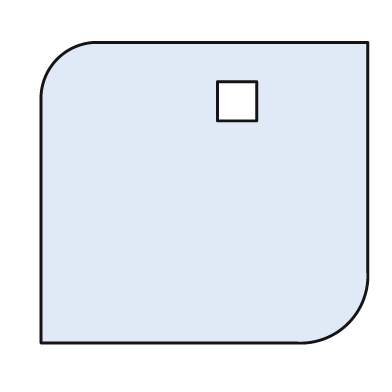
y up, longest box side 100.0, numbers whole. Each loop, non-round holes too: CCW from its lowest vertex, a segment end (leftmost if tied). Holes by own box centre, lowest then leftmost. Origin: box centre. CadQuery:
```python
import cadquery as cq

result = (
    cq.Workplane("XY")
    .moveTo(-50.0, -46.0)
    .lineTo(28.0, -46.0)
    .threePointArc((44.0, -40.0), (50.0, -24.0))
    .lineTo(50.0, 46.0)
    .lineTo(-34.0, 46.0)
    .threePointArc((-45.0, 41.0), (-50.0, 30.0))
    .close()
    .moveTo(4.0, 22.0)
    .lineTo(16.0, 22.0)
    .lineTo(16.0, 34.0)
    .lineTo(4.0, 34.0)
    .close()
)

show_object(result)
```